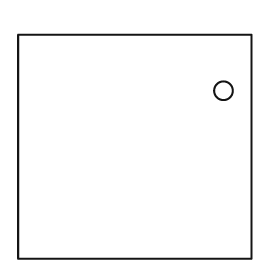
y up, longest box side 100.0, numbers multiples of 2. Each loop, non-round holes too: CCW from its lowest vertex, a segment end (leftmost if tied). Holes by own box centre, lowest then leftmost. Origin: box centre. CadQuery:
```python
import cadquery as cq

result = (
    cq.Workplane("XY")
    .moveTo(-50.0, -48.0)
    .lineTo(50.0, -48.0)
    .lineTo(50.0, 48.0)
    .lineTo(-50.0, 48.0)
    .close()
    .moveTo(38.0, 24.0)
    .circle(4.0)
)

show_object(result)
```